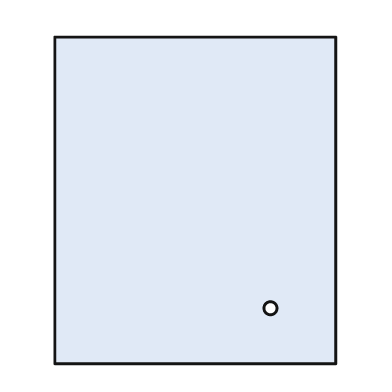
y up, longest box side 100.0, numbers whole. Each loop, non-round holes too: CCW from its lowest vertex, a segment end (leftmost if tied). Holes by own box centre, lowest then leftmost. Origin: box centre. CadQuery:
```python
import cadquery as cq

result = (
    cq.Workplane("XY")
    .moveTo(-43.0, -50.0)
    .lineTo(43.0, -50.0)
    .lineTo(43.0, 50.0)
    .lineTo(-43.0, 50.0)
    .close()
    .moveTo(23.0, -33.0)
    .circle(2.0)
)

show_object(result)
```